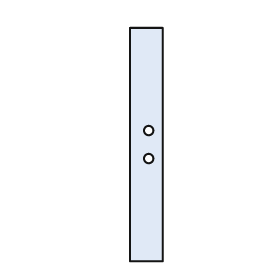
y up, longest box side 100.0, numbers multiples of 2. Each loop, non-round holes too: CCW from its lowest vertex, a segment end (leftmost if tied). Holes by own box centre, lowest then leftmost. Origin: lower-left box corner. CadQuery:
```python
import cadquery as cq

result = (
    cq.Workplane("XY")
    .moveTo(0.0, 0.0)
    .lineTo(14.0, 0.0)
    .lineTo(14.0, 100.0)
    .lineTo(0.0, 100.0)
    .close()
    .moveTo(8.0, 44.0)
    .circle(2.0)
    .moveTo(8.0, 56.0)
    .circle(2.0)
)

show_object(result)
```